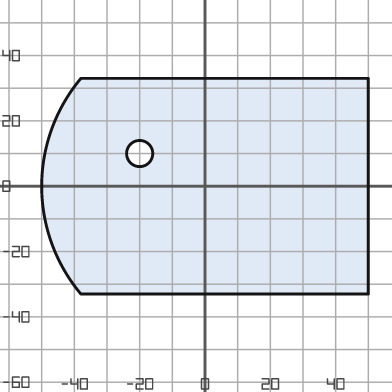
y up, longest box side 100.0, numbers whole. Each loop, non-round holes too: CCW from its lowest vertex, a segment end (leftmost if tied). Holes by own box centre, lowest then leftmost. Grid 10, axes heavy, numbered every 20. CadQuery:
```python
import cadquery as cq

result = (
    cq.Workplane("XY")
    .moveTo(-38.0, -33.0)
    .lineTo(50.0, -33.0)
    .lineTo(50.0, 33.0)
    .lineTo(-38.0, 33.0)
    .threePointArc((-50.0, 0.0), (-38.0, -33.0))
    .close()
    .moveTo(-20.0, 10.0)
    .circle(4.0)
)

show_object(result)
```